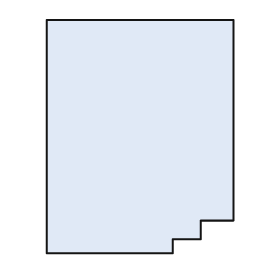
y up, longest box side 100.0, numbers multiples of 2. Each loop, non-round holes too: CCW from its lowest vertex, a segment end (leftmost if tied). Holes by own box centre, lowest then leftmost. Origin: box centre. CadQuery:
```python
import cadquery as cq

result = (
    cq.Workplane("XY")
    .moveTo(-40.0, -50.0)
    .lineTo(14.0, -50.0)
    .lineTo(14.0, -44.0)
    .lineTo(26.0, -44.0)
    .lineTo(26.0, -36.0)
    .lineTo(40.0, -36.0)
    .lineTo(40.0, 50.0)
    .lineTo(-40.0, 50.0)
    .close()
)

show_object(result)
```